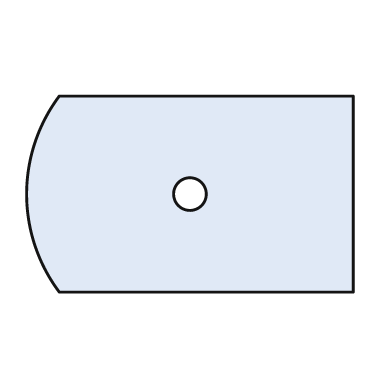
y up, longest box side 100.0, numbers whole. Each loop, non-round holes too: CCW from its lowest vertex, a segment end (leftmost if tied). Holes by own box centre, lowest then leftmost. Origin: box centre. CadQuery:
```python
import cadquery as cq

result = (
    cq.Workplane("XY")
    .moveTo(-40.0, -30.0)
    .lineTo(50.0, -30.0)
    .lineTo(50.0, 30.0)
    .lineTo(-40.0, 30.0)
    .threePointArc((-50.0, 0.0), (-40.0, -30.0))
    .close()
    .moveTo(0.0, 0.0)
    .circle(5.0)
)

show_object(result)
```